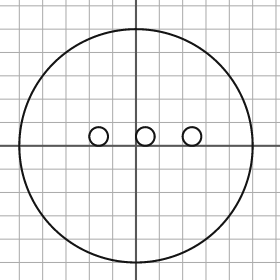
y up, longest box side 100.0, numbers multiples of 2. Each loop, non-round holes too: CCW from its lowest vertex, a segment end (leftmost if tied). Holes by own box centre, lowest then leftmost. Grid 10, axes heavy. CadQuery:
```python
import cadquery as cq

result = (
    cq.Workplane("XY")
    .moveTo(0.0, 0.0)
    .circle(50.0)
    .moveTo(-16.0, 4.0)
    .circle(4.0)
    .moveTo(4.0, 4.0)
    .circle(4.0)
    .moveTo(24.0, 4.0)
    .circle(4.0)
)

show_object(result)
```